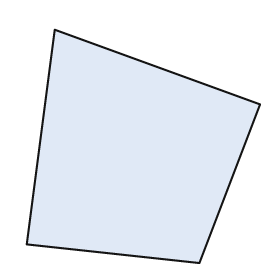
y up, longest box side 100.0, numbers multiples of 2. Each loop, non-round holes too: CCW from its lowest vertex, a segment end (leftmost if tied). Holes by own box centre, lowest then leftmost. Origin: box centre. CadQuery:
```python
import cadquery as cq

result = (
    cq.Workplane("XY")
    .moveTo(24.0, -50.0)
    .lineTo(50.0, 18.0)
    .lineTo(-38.0, 50.0)
    .lineTo(-50.0, -42.0)
    .close()
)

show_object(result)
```